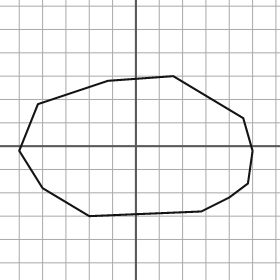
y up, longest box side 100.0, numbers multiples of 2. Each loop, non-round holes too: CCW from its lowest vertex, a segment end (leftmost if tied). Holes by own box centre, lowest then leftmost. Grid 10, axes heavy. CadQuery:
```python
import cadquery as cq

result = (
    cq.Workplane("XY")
    .moveTo(-20.0, -30.0)
    .lineTo(28.0, -28.0)
    .lineTo(40.0, -22.0)
    .lineTo(48.0, -16.0)
    .lineTo(50.0, -2.0)
    .lineTo(46.0, 12.0)
    .lineTo(16.0, 30.0)
    .lineTo(-12.0, 28.0)
    .lineTo(-42.0, 18.0)
    .lineTo(-50.0, -2.0)
    .lineTo(-40.0, -18.0)
    .close()
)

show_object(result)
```